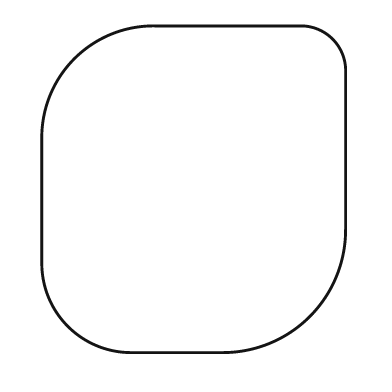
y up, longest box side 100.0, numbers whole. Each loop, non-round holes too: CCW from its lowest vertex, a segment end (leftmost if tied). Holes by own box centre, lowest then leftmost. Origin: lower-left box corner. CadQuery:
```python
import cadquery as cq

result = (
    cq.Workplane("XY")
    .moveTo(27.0, 0.0)
    .lineTo(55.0, 0.0)
    .threePointArc((82.0, 11.0), (93.0, 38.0))
    .lineTo(93.0, 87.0)
    .threePointArc((89.0, 96.0), (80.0, 100.0))
    .lineTo(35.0, 100.0)
    .threePointArc((10.0, 90.0), (0.0, 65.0))
    .lineTo(0.0, 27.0)
    .threePointArc((8.0, 8.0), (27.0, 0.0))
    .close()
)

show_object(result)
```